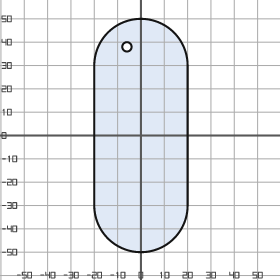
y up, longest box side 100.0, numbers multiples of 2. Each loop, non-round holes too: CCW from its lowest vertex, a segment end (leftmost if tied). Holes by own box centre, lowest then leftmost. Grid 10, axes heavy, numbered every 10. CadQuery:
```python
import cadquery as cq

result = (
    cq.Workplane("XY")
    .moveTo(-20.0, -30.0)
    .threePointArc((0.0, -50.0), (20.0, -30.0))
    .lineTo(20.0, 30.0)
    .threePointArc((0.0, 50.0), (-20.0, 30.0))
    .close()
    .moveTo(-6.0, 38.0)
    .circle(2.0)
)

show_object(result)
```